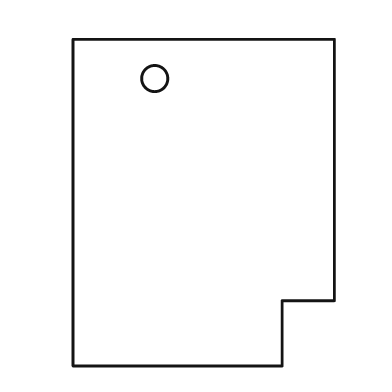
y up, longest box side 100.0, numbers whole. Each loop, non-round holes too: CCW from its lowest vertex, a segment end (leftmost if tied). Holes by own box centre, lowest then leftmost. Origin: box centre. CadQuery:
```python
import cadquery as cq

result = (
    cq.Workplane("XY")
    .moveTo(-40.0, -50.0)
    .lineTo(24.0, -50.0)
    .lineTo(24.0, -30.0)
    .lineTo(40.0, -30.0)
    .lineTo(40.0, 50.0)
    .lineTo(-40.0, 50.0)
    .close()
    .moveTo(-15.0, 38.0)
    .circle(4.0)
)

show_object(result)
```